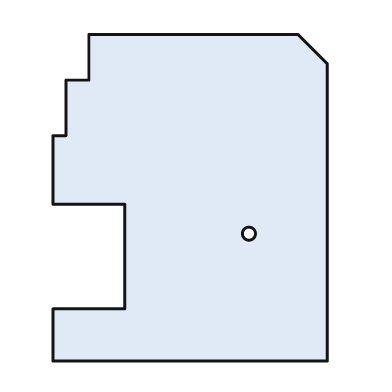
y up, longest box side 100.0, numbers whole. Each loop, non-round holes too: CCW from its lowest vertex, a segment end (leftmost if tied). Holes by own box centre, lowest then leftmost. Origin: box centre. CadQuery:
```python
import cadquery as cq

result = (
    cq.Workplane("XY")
    .moveTo(-42.0, -50.0)
    .lineTo(42.0, -50.0)
    .lineTo(42.0, 41.0)
    .lineTo(33.0, 50.0)
    .lineTo(-31.0, 50.0)
    .lineTo(-31.0, 36.0)
    .lineTo(-38.0, 36.0)
    .lineTo(-38.0, 19.0)
    .lineTo(-42.0, 19.0)
    .lineTo(-42.0, -2.0)
    .lineTo(-20.0, -2.0)
    .lineTo(-20.0, -34.0)
    .lineTo(-42.0, -34.0)
    .close()
    .moveTo(18.0, -11.0)
    .circle(2.0)
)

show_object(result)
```